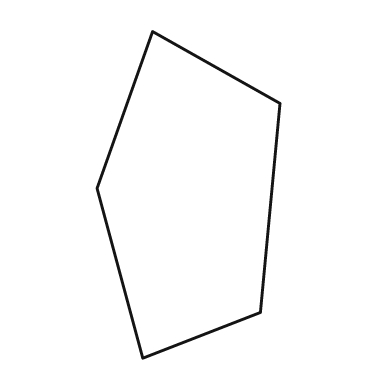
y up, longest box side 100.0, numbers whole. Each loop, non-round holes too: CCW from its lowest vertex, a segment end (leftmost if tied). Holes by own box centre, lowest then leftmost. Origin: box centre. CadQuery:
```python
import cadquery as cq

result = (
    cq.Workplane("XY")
    .moveTo(-14.0, -50.0)
    .lineTo(22.0, -36.0)
    .lineTo(28.0, 28.0)
    .lineTo(-11.0, 50.0)
    .lineTo(-28.0, 2.0)
    .close()
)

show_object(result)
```